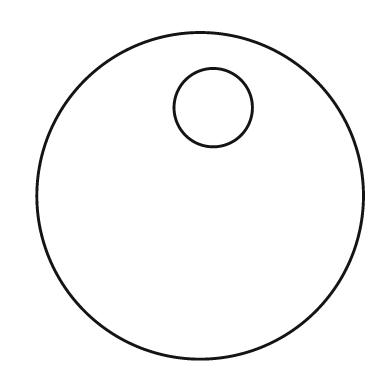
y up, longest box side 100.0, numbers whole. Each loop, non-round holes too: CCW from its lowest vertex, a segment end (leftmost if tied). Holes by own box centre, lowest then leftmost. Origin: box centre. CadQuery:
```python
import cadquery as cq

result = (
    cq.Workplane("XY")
    .moveTo(0.0, 0.0)
    .circle(50.0)
    .moveTo(4.0, 27.0)
    .circle(12.0)
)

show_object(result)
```